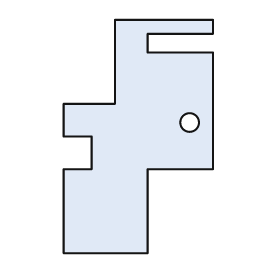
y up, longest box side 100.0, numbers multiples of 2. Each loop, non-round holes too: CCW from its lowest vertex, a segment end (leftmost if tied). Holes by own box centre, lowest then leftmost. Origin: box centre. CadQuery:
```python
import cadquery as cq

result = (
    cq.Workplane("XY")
    .moveTo(-32.0, -50.0)
    .lineTo(4.0, -50.0)
    .lineTo(4.0, -14.0)
    .lineTo(32.0, -14.0)
    .lineTo(32.0, 36.0)
    .lineTo(4.0, 36.0)
    .lineTo(4.0, 44.0)
    .lineTo(32.0, 44.0)
    .lineTo(32.0, 50.0)
    .lineTo(-10.0, 50.0)
    .lineTo(-10.0, 14.0)
    .lineTo(-32.0, 14.0)
    .lineTo(-32.0, 0.0)
    .lineTo(-20.0, 0.0)
    .lineTo(-20.0, -14.0)
    .lineTo(-32.0, -14.0)
    .close()
    .moveTo(22.0, 6.0)
    .circle(4.0)
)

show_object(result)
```